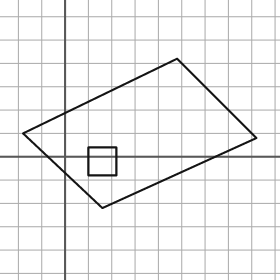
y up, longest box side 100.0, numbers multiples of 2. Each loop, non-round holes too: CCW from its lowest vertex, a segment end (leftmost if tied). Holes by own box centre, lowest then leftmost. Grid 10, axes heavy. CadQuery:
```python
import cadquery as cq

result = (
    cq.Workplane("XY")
    .moveTo(16.0, -22.0)
    .lineTo(82.0, 8.0)
    .lineTo(48.0, 42.0)
    .lineTo(-18.0, 10.0)
    .close()
    .moveTo(10.0, -8.0)
    .lineTo(22.0, -8.0)
    .lineTo(22.0, 4.0)
    .lineTo(10.0, 4.0)
    .close()
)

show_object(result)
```